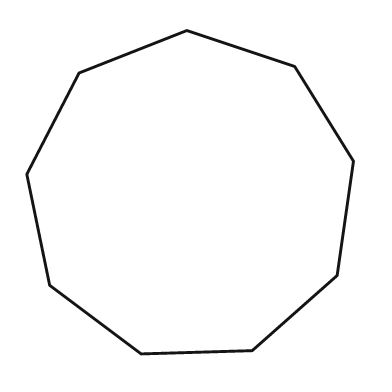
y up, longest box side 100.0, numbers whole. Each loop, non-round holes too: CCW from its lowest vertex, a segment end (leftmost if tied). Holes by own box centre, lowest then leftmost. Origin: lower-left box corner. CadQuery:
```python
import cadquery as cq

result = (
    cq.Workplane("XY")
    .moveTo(35.0, 0.0)
    .lineTo(69.0, 1.0)
    .lineTo(95.0, 24.0)
    .lineTo(100.0, 59.0)
    .lineTo(82.0, 88.0)
    .lineTo(49.0, 99.0)
    .lineTo(16.0, 86.0)
    .lineTo(0.0, 55.0)
    .lineTo(7.0, 21.0)
    .close()
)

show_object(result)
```